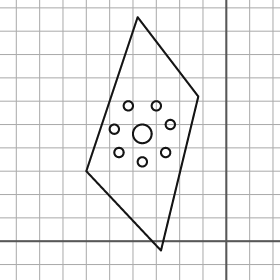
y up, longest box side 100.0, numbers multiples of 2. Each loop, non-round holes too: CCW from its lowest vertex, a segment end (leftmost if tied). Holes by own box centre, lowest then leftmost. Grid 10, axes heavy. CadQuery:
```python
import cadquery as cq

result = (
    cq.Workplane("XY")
    .moveTo(-28.0, -4.0)
    .lineTo(-12.0, 62.0)
    .lineTo(-38.0, 96.0)
    .lineTo(-60.0, 30.0)
    .close()
    .moveTo(-36.0, 34.0)
    .circle(2.0)
    .moveTo(-46.0, 38.0)
    .circle(2.0)
    .moveTo(-26.0, 38.0)
    .circle(2.0)
    .moveTo(-36.0, 46.0)
    .circle(4.0)
    .moveTo(-48.0, 48.0)
    .circle(2.0)
    .moveTo(-24.0, 50.0)
    .circle(2.0)
    .moveTo(-42.0, 58.0)
    .circle(2.0)
    .moveTo(-30.0, 58.0)
    .circle(2.0)
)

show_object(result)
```